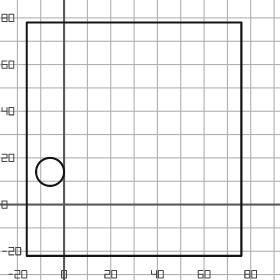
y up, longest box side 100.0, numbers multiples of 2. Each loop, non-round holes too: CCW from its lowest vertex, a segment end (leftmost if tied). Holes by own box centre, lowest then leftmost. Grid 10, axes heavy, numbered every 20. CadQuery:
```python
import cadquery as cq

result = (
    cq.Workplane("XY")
    .moveTo(-16.0, -22.0)
    .lineTo(76.0, -22.0)
    .lineTo(76.0, 78.0)
    .lineTo(-16.0, 78.0)
    .close()
    .moveTo(-6.0, 14.0)
    .circle(6.0)
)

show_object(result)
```